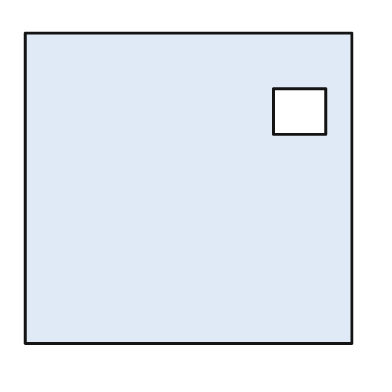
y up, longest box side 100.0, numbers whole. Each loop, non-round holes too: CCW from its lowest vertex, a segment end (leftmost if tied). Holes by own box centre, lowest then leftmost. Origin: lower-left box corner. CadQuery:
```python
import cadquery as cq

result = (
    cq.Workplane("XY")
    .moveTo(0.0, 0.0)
    .lineTo(100.0, 0.0)
    .lineTo(100.0, 95.0)
    .lineTo(0.0, 95.0)
    .close()
    .moveTo(76.0, 64.0)
    .lineTo(92.0, 64.0)
    .lineTo(92.0, 78.0)
    .lineTo(76.0, 78.0)
    .close()
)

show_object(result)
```